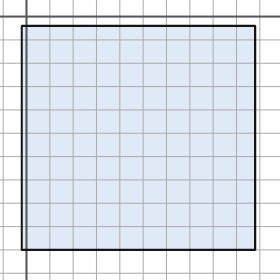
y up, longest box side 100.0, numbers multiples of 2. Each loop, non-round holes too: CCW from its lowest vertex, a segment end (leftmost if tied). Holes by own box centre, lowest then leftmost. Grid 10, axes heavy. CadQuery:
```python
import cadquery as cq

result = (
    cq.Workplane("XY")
    .moveTo(-2.0, -100.0)
    .lineTo(98.0, -100.0)
    .lineTo(98.0, -4.0)
    .lineTo(-2.0, -4.0)
    .close()
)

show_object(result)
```